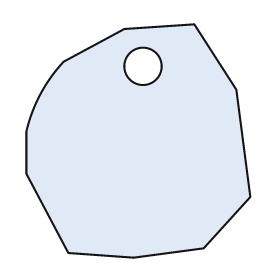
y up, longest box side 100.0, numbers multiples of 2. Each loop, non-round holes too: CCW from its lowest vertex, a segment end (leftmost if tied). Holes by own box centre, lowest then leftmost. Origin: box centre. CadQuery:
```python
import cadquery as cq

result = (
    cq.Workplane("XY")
    .moveTo(-2.0, -50.0)
    .lineTo(28.0, -46.0)
    .lineTo(48.0, -24.0)
    .lineTo(42.0, 22.0)
    .lineTo(24.0, 50.0)
    .lineTo(-6.0, 48.0)
    .lineTo(-32.0, 34.0)
    .threePointArc((-42.0, 20.0), (-48.0, 4.0))
    .lineTo(-48.0, -14.0)
    .lineTo(-30.0, -48.0)
    .close()
    .moveTo(2.0, 32.0)
    .circle(8.0)
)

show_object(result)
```